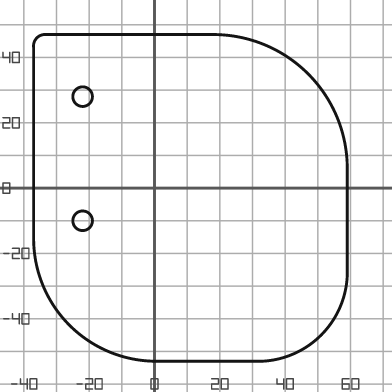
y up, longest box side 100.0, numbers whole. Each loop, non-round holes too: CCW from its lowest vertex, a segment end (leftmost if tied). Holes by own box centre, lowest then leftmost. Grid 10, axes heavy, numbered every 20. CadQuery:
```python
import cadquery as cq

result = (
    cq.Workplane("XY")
    .moveTo(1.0, -53.0)
    .lineTo(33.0, -53.0)
    .threePointArc((51.0, -45.0), (59.0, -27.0))
    .lineTo(59.0, 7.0)
    .threePointArc((47.0, 35.0), (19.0, 47.0))
    .lineTo(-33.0, 47.0)
    .threePointArc((-36.0, 46.0), (-37.0, 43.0))
    .lineTo(-37.0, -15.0)
    .threePointArc((-26.0, -42.0), (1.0, -53.0))
    .close()
    .moveTo(-22.0, -10.0)
    .circle(3.0)
    .moveTo(-22.0, 28.0)
    .circle(3.0)
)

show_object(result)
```